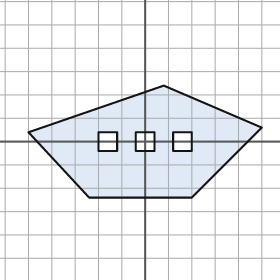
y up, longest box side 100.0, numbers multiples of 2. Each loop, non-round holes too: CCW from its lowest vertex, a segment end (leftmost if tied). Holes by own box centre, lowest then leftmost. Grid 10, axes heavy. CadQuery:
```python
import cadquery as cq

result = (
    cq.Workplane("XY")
    .moveTo(-24.0, -24.0)
    .lineTo(20.0, -24.0)
    .lineTo(50.0, 6.0)
    .lineTo(8.0, 24.0)
    .lineTo(-50.0, 4.0)
    .close()
    .moveTo(-20.0, -4.0)
    .lineTo(-12.0, -4.0)
    .lineTo(-12.0, 4.0)
    .lineTo(-20.0, 4.0)
    .close()
    .moveTo(-4.0, -4.0)
    .lineTo(4.0, -4.0)
    .lineTo(4.0, 4.0)
    .lineTo(-4.0, 4.0)
    .close()
    .moveTo(12.0, -4.0)
    .lineTo(20.0, -4.0)
    .lineTo(20.0, 4.0)
    .lineTo(12.0, 4.0)
    .close()
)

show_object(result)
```